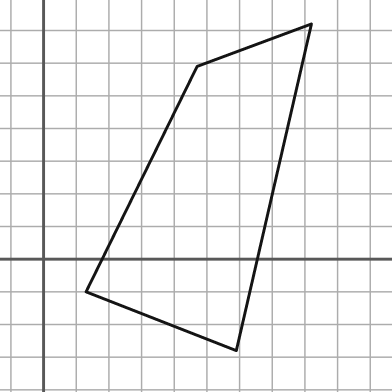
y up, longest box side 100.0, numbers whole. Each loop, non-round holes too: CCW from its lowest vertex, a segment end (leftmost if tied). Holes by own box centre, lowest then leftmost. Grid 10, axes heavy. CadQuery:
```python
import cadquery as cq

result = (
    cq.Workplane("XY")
    .moveTo(59.0, -28.0)
    .lineTo(82.0, 72.0)
    .lineTo(47.0, 59.0)
    .lineTo(13.0, -10.0)
    .close()
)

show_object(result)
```